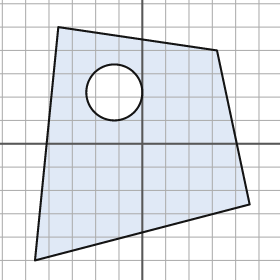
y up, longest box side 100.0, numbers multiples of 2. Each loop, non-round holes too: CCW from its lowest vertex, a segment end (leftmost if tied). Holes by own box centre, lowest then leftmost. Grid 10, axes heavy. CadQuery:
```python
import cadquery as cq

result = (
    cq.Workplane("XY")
    .moveTo(-46.0, -50.0)
    .lineTo(46.0, -26.0)
    .lineTo(32.0, 40.0)
    .lineTo(-36.0, 50.0)
    .close()
    .moveTo(-12.0, 22.0)
    .circle(12.0)
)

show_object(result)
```